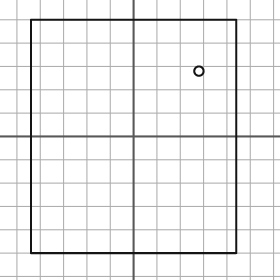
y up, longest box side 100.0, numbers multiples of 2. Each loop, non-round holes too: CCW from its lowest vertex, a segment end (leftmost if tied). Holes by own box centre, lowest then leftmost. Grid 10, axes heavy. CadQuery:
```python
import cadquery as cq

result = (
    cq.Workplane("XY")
    .moveTo(-44.0, -50.0)
    .lineTo(44.0, -50.0)
    .lineTo(44.0, 50.0)
    .lineTo(-44.0, 50.0)
    .close()
    .moveTo(28.0, 28.0)
    .circle(2.0)
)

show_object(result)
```